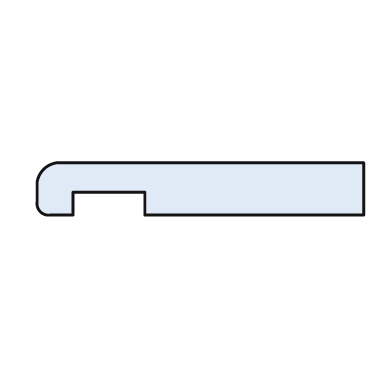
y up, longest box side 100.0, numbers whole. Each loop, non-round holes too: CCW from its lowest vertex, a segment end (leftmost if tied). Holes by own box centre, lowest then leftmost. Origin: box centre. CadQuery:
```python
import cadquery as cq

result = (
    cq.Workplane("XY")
    .moveTo(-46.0, -8.0)
    .lineTo(-39.0, -8.0)
    .lineTo(-39.0, -1.0)
    .lineTo(-17.0, -1.0)
    .lineTo(-17.0, -8.0)
    .lineTo(50.0, -8.0)
    .lineTo(50.0, 8.0)
    .lineTo(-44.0, 8.0)
    .threePointArc((-48.0, 6.0), (-50.0, 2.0))
    .lineTo(-50.0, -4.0)
    .threePointArc((-49.0, -7.0), (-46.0, -8.0))
    .close()
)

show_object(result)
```